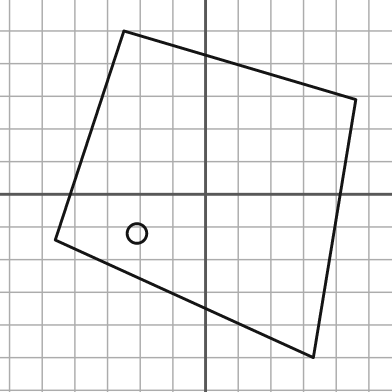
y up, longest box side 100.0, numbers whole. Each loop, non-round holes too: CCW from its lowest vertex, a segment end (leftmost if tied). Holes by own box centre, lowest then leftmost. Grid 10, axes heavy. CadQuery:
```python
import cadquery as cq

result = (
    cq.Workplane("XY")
    .moveTo(33.0, -50.0)
    .lineTo(46.0, 29.0)
    .lineTo(-25.0, 50.0)
    .lineTo(-46.0, -14.0)
    .close()
    .moveTo(-21.0, -12.0)
    .circle(3.0)
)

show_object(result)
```